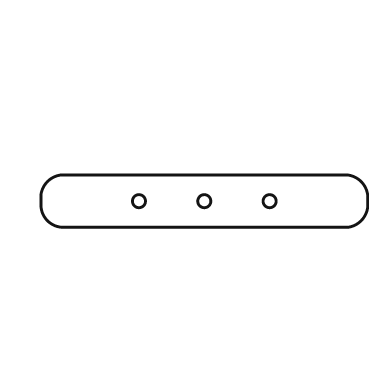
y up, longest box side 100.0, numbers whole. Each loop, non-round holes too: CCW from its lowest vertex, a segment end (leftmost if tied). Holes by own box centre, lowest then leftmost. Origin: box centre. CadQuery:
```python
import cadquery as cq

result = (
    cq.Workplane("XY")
    .moveTo(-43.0, -8.0)
    .lineTo(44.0, -8.0)
    .threePointArc((48.0, -6.0), (50.0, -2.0))
    .lineTo(50.0, 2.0)
    .threePointArc((48.0, 6.0), (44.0, 8.0))
    .lineTo(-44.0, 8.0)
    .threePointArc((-48.0, 6.0), (-50.0, 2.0))
    .lineTo(-50.0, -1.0)
    .threePointArc((-48.0, -6.0), (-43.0, -8.0))
    .close()
    .moveTo(-20.0, 0.0)
    .circle(2.0)
    .moveTo(0.0, 0.0)
    .circle(2.0)
    .moveTo(20.0, 0.0)
    .circle(2.0)
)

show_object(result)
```